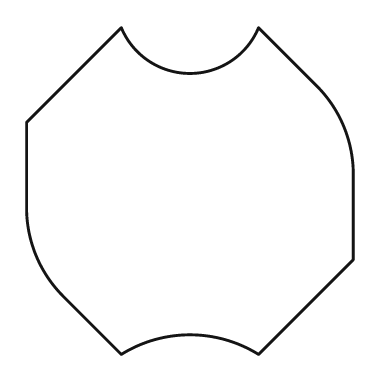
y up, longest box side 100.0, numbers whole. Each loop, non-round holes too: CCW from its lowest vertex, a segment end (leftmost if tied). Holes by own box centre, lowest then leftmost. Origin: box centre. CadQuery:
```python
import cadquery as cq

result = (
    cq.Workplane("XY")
    .moveTo(-21.0, -50.0)
    .threePointArc((0.0, -44.0), (21.0, -50.0))
    .lineTo(50.0, -21.0)
    .lineTo(50.0, 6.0)
    .threePointArc((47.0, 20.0), (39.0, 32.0))
    .lineTo(21.0, 50.0)
    .threePointArc((0.0, 36.0), (-21.0, 50.0))
    .lineTo(-50.0, 21.0)
    .lineTo(-50.0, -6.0)
    .threePointArc((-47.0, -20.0), (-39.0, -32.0))
    .close()
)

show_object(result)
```